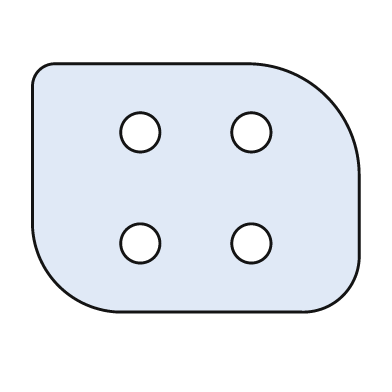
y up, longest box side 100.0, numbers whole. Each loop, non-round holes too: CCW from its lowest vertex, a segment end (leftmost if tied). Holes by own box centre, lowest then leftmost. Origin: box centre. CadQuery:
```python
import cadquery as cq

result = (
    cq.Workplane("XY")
    .moveTo(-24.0, -38.0)
    .lineTo(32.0, -38.0)
    .threePointArc((45.0, -33.0), (50.0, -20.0))
    .lineTo(50.0, 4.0)
    .threePointArc((40.0, 28.0), (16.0, 38.0))
    .lineTo(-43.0, 38.0)
    .threePointArc((-48.0, 36.0), (-50.0, 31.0))
    .lineTo(-50.0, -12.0)
    .threePointArc((-42.0, -30.0), (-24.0, -38.0))
    .close()
    .moveTo(-17.0, -17.0)
    .circle(6.0)
    .moveTo(17.0, -17.0)
    .circle(6.0)
    .moveTo(-17.0, 17.0)
    .circle(6.0)
    .moveTo(17.0, 17.0)
    .circle(6.0)
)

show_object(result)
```